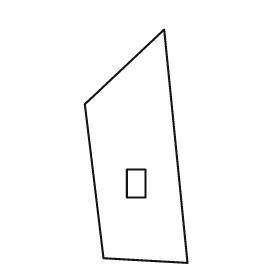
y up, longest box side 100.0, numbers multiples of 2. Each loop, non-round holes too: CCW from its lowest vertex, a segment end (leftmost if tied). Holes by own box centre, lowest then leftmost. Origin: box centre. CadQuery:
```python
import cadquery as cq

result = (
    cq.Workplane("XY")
    .moveTo(22.0, -50.0)
    .lineTo(12.0, 50.0)
    .lineTo(-22.0, 18.0)
    .lineTo(-14.0, -48.0)
    .close()
    .moveTo(-4.0, -22.0)
    .lineTo(4.0, -22.0)
    .lineTo(4.0, -10.0)
    .lineTo(-4.0, -10.0)
    .close()
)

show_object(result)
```